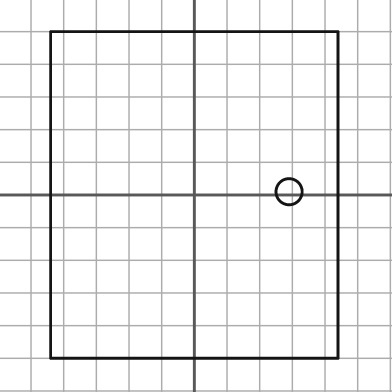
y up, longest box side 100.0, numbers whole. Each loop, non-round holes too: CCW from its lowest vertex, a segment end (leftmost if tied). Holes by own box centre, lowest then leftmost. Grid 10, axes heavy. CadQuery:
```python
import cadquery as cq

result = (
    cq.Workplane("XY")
    .moveTo(-44.0, -50.0)
    .lineTo(44.0, -50.0)
    .lineTo(44.0, 50.0)
    .lineTo(-44.0, 50.0)
    .close()
    .moveTo(29.0, 1.0)
    .circle(4.0)
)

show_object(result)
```